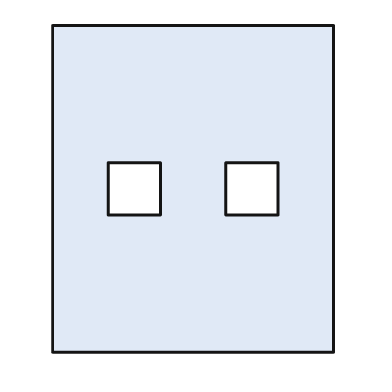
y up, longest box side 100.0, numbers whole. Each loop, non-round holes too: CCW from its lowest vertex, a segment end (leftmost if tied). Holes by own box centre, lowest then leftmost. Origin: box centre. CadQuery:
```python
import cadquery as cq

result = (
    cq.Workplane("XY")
    .moveTo(-43.0, -50.0)
    .lineTo(43.0, -50.0)
    .lineTo(43.0, 50.0)
    .lineTo(-43.0, 50.0)
    .close()
    .moveTo(-26.0, -8.0)
    .lineTo(-10.0, -8.0)
    .lineTo(-10.0, 8.0)
    .lineTo(-26.0, 8.0)
    .close()
    .moveTo(10.0, -8.0)
    .lineTo(26.0, -8.0)
    .lineTo(26.0, 8.0)
    .lineTo(10.0, 8.0)
    .close()
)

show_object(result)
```